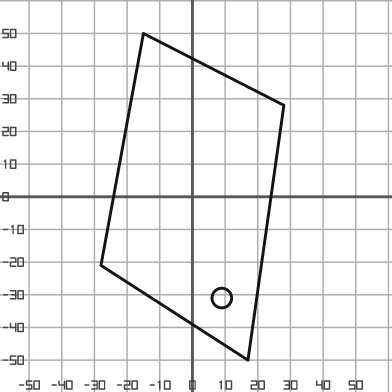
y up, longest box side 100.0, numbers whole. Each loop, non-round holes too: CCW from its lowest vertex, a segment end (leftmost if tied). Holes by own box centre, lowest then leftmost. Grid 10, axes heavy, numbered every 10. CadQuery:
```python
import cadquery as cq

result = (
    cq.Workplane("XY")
    .moveTo(17.0, -50.0)
    .lineTo(28.0, 28.0)
    .lineTo(-15.0, 50.0)
    .lineTo(-28.0, -21.0)
    .close()
    .moveTo(9.0, -31.0)
    .circle(3.0)
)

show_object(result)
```